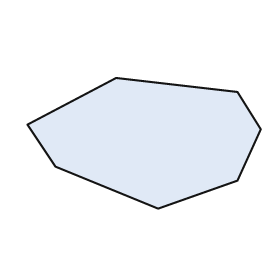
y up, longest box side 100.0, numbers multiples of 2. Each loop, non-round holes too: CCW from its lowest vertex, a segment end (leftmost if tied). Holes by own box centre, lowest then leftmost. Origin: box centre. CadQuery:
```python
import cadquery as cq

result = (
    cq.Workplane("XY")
    .moveTo(6.0, -28.0)
    .lineTo(40.0, -16.0)
    .lineTo(50.0, 6.0)
    .lineTo(40.0, 22.0)
    .lineTo(-12.0, 28.0)
    .lineTo(-50.0, 8.0)
    .lineTo(-38.0, -10.0)
    .close()
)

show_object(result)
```